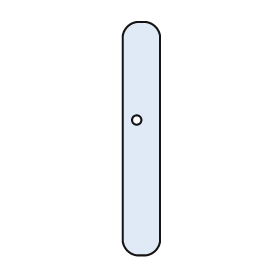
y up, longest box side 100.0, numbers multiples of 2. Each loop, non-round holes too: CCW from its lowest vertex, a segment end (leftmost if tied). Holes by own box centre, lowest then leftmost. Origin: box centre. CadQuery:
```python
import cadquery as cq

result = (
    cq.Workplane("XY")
    .moveTo(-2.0, -50.0)
    .lineTo(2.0, -50.0)
    .threePointArc((6.0, -48.0), (8.0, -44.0))
    .lineTo(8.0, 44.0)
    .threePointArc((6.0, 48.0), (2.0, 50.0))
    .lineTo(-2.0, 50.0)
    .threePointArc((-6.0, 48.0), (-8.0, 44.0))
    .lineTo(-8.0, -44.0)
    .threePointArc((-6.0, -48.0), (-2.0, -50.0))
    .close()
    .moveTo(-2.0, 8.0)
    .circle(2.0)
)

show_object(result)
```